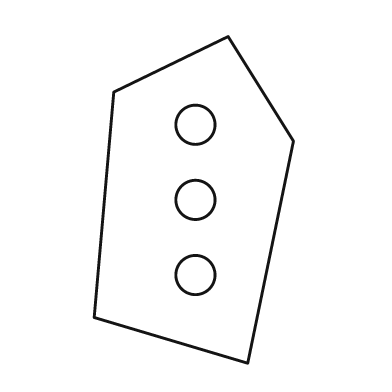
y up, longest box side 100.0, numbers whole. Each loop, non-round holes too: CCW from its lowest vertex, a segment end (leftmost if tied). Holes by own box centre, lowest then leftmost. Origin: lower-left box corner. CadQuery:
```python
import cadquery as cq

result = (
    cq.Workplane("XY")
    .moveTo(47.0, 0.0)
    .lineTo(61.0, 68.0)
    .lineTo(41.0, 100.0)
    .lineTo(6.0, 83.0)
    .lineTo(0.0, 14.0)
    .close()
    .moveTo(31.0, 27.0)
    .circle(6.0)
    .moveTo(31.0, 50.0)
    .circle(6.0)
    .moveTo(31.0, 73.0)
    .circle(6.0)
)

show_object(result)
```